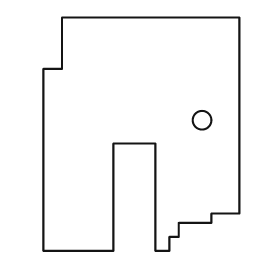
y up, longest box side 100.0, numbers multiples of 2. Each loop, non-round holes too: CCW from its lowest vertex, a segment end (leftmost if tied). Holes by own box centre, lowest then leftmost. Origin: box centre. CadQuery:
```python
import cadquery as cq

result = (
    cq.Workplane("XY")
    .moveTo(-42.0, -50.0)
    .lineTo(-12.0, -50.0)
    .lineTo(-12.0, -4.0)
    .lineTo(6.0, -4.0)
    .lineTo(6.0, -50.0)
    .lineTo(12.0, -50.0)
    .lineTo(12.0, -44.0)
    .lineTo(16.0, -44.0)
    .lineTo(16.0, -38.0)
    .lineTo(30.0, -38.0)
    .lineTo(30.0, -34.0)
    .lineTo(42.0, -34.0)
    .lineTo(42.0, 50.0)
    .lineTo(-34.0, 50.0)
    .lineTo(-34.0, 28.0)
    .lineTo(-42.0, 28.0)
    .close()
    .moveTo(26.0, 6.0)
    .circle(4.0)
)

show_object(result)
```